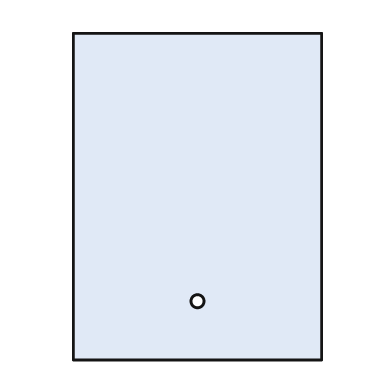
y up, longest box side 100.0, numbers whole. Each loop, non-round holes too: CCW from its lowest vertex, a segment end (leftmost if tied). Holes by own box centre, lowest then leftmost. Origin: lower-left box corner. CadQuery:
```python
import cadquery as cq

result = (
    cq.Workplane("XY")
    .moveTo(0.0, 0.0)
    .lineTo(76.0, 0.0)
    .lineTo(76.0, 100.0)
    .lineTo(0.0, 100.0)
    .close()
    .moveTo(38.0, 18.0)
    .circle(2.0)
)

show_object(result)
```